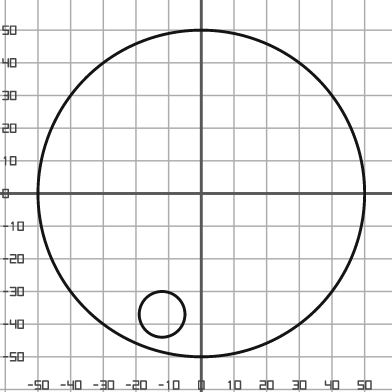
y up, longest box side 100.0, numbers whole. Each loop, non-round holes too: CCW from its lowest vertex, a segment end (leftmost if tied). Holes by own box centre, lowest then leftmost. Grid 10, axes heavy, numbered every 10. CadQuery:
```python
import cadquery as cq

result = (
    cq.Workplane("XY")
    .moveTo(0.0, 0.0)
    .circle(50.0)
    .moveTo(-12.0, -37.0)
    .circle(7.0)
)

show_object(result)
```